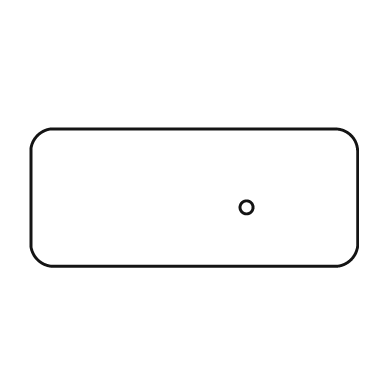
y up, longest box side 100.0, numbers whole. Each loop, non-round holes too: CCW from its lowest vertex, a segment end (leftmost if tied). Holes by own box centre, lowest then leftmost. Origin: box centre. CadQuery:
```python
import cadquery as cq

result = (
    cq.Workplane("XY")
    .moveTo(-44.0, -21.0)
    .lineTo(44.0, -21.0)
    .threePointArc((48.0, -19.0), (50.0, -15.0))
    .lineTo(50.0, 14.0)
    .threePointArc((48.0, 19.0), (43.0, 21.0))
    .lineTo(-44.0, 21.0)
    .threePointArc((-48.0, 19.0), (-50.0, 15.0))
    .lineTo(-50.0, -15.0)
    .threePointArc((-48.0, -19.0), (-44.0, -21.0))
    .close()
    .moveTo(16.0, -3.0)
    .circle(2.0)
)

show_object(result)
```